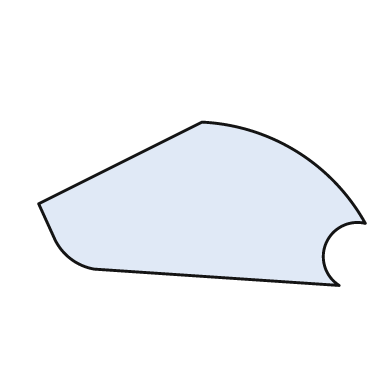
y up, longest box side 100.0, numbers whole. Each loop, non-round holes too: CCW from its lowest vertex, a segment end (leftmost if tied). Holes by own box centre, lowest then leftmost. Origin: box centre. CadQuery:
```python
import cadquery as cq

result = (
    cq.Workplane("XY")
    .moveTo(42.0, -25.0)
    .threePointArc((38.0, -12.0), (50.0, -6.0))
    .threePointArc((29.0, 16.0), (0.0, 25.0))
    .lineTo(-50.0, 0.0)
    .lineTo(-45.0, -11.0)
    .threePointArc((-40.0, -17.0), (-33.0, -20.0))
    .close()
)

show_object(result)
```